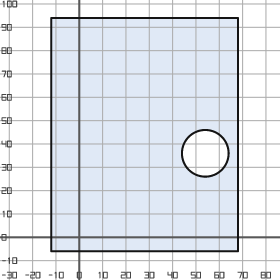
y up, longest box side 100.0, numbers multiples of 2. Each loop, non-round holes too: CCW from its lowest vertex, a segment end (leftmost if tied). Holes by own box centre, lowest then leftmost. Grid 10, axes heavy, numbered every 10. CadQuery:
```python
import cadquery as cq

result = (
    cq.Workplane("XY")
    .moveTo(-12.0, -6.0)
    .lineTo(68.0, -6.0)
    .lineTo(68.0, 94.0)
    .lineTo(-12.0, 94.0)
    .close()
    .moveTo(54.0, 36.0)
    .circle(10.0)
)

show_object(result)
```